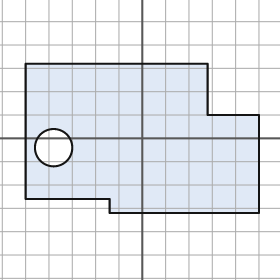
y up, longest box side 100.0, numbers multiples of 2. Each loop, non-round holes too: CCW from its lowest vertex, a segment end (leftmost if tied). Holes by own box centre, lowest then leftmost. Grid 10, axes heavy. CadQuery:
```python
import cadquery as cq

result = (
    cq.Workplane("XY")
    .moveTo(-14.0, -32.0)
    .lineTo(50.0, -32.0)
    .lineTo(50.0, 10.0)
    .lineTo(28.0, 10.0)
    .lineTo(28.0, 32.0)
    .lineTo(-50.0, 32.0)
    .lineTo(-50.0, -26.0)
    .lineTo(-14.0, -26.0)
    .close()
    .moveTo(-38.0, -4.0)
    .circle(8.0)
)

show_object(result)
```